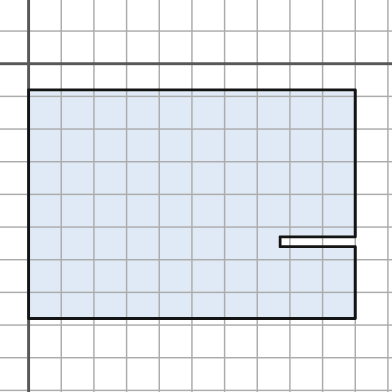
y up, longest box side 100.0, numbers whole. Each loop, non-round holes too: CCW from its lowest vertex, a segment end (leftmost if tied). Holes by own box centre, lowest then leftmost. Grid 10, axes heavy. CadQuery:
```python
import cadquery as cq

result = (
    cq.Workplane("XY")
    .moveTo(0.0, -78.0)
    .lineTo(100.0, -78.0)
    .lineTo(100.0, -56.0)
    .lineTo(77.0, -56.0)
    .lineTo(77.0, -53.0)
    .lineTo(100.0, -53.0)
    .lineTo(100.0, -8.0)
    .lineTo(0.0, -8.0)
    .close()
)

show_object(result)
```